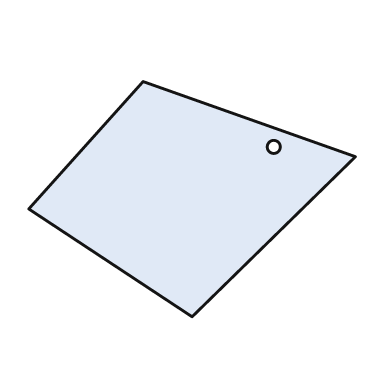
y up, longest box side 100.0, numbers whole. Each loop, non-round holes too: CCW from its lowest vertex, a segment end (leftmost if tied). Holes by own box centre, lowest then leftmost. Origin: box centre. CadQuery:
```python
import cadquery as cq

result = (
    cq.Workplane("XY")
    .moveTo(0.0, -36.0)
    .lineTo(50.0, 13.0)
    .lineTo(-15.0, 36.0)
    .lineTo(-50.0, -3.0)
    .close()
    .moveTo(25.0, 16.0)
    .circle(2.0)
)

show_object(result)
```